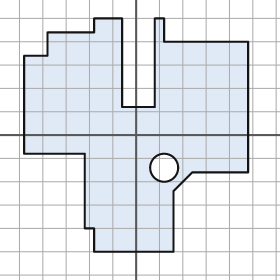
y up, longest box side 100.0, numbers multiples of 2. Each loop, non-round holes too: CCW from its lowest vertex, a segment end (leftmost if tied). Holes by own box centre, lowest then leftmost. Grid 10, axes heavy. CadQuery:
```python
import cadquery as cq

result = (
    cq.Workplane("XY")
    .moveTo(-18.0, -50.0)
    .lineTo(16.0, -50.0)
    .lineTo(16.0, -24.0)
    .lineTo(24.0, -16.0)
    .lineTo(48.0, -16.0)
    .lineTo(48.0, 40.0)
    .lineTo(12.0, 40.0)
    .lineTo(12.0, 50.0)
    .lineTo(8.0, 50.0)
    .lineTo(8.0, 12.0)
    .lineTo(-6.0, 12.0)
    .lineTo(-6.0, 50.0)
    .lineTo(-18.0, 50.0)
    .lineTo(-18.0, 44.0)
    .lineTo(-38.0, 44.0)
    .lineTo(-38.0, 34.0)
    .lineTo(-48.0, 34.0)
    .lineTo(-48.0, -8.0)
    .lineTo(-22.0, -8.0)
    .lineTo(-22.0, -40.0)
    .lineTo(-18.0, -40.0)
    .close()
    .moveTo(12.0, -14.0)
    .circle(6.0)
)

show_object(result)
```